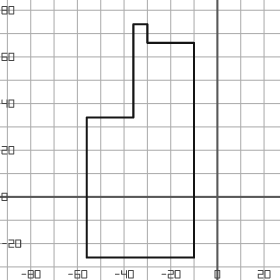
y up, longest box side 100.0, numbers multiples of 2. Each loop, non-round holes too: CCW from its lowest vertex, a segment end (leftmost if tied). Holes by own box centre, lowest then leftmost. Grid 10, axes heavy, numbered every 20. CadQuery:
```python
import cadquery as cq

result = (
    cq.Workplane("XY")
    .moveTo(-56.0, -26.0)
    .lineTo(-10.0, -26.0)
    .lineTo(-10.0, 66.0)
    .lineTo(-30.0, 66.0)
    .lineTo(-30.0, 74.0)
    .lineTo(-36.0, 74.0)
    .lineTo(-36.0, 34.0)
    .lineTo(-56.0, 34.0)
    .close()
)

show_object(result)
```